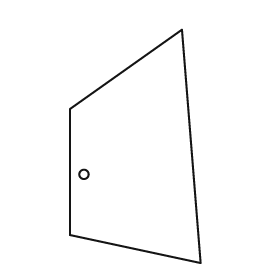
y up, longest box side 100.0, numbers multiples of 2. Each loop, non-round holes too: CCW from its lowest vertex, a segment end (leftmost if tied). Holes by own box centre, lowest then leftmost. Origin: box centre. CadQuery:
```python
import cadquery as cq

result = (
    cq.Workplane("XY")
    .moveTo(28.0, -50.0)
    .lineTo(20.0, 50.0)
    .lineTo(-28.0, 16.0)
    .lineTo(-28.0, -38.0)
    .close()
    .moveTo(-22.0, -12.0)
    .circle(2.0)
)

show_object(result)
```